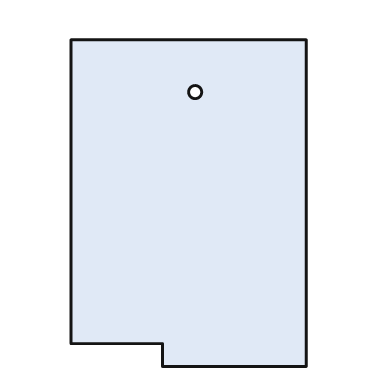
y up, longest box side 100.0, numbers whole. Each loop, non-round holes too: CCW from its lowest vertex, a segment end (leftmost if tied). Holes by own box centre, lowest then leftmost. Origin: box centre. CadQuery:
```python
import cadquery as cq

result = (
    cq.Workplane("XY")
    .moveTo(-8.0, -50.0)
    .lineTo(36.0, -50.0)
    .lineTo(36.0, 50.0)
    .lineTo(-36.0, 50.0)
    .lineTo(-36.0, -43.0)
    .lineTo(-8.0, -43.0)
    .close()
    .moveTo(2.0, 34.0)
    .circle(2.0)
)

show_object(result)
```